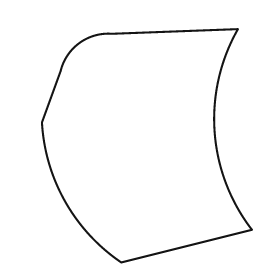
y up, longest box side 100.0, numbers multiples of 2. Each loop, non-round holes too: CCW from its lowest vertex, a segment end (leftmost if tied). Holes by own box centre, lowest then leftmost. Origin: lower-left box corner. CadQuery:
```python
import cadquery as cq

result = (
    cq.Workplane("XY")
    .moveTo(34.0, 0.0)
    .lineTo(90.0, 14.0)
    .threePointArc((74.0, 56.0), (84.0, 100.0))
    .lineTo(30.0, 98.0)
    .threePointArc((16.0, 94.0), (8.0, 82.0))
    .lineTo(0.0, 60.0)
    .threePointArc((10.0, 26.0), (34.0, 0.0))
    .close()
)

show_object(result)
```